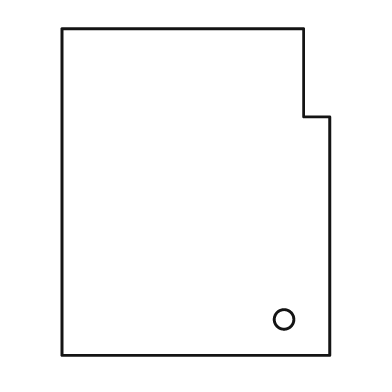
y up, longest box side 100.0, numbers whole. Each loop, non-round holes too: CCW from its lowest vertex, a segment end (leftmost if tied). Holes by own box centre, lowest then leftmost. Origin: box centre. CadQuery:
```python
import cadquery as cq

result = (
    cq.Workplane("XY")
    .moveTo(-41.0, -50.0)
    .lineTo(41.0, -50.0)
    .lineTo(41.0, 23.0)
    .lineTo(33.0, 23.0)
    .lineTo(33.0, 50.0)
    .lineTo(-41.0, 50.0)
    .close()
    .moveTo(27.0, -39.0)
    .circle(3.0)
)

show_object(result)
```